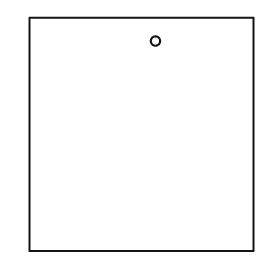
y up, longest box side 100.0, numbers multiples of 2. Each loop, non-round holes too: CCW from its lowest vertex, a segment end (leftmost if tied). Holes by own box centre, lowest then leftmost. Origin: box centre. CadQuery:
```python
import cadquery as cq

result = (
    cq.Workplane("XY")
    .moveTo(-48.0, -50.0)
    .lineTo(48.0, -50.0)
    .lineTo(48.0, 50.0)
    .lineTo(-48.0, 50.0)
    .close()
    .moveTo(6.0, 40.0)
    .circle(2.0)
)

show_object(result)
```